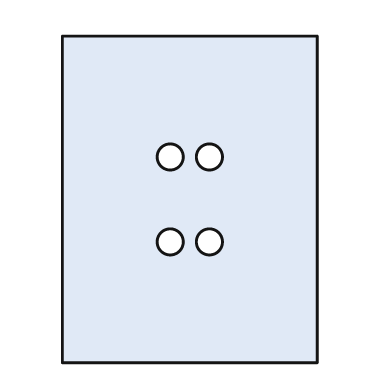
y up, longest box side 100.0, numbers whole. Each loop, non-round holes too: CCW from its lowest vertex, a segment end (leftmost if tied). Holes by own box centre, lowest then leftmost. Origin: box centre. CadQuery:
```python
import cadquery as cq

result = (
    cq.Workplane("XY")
    .moveTo(-39.0, -50.0)
    .lineTo(39.0, -50.0)
    .lineTo(39.0, 50.0)
    .lineTo(-39.0, 50.0)
    .close()
    .moveTo(-6.0, -13.0)
    .circle(4.0)
    .moveTo(6.0, -13.0)
    .circle(4.0)
    .moveTo(-6.0, 13.0)
    .circle(4.0)
    .moveTo(6.0, 13.0)
    .circle(4.0)
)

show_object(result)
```